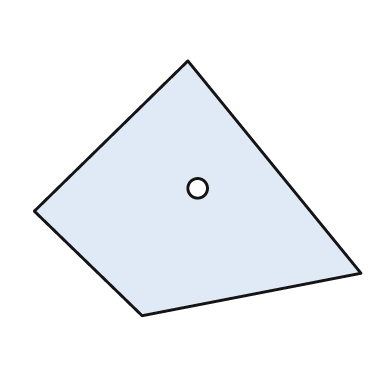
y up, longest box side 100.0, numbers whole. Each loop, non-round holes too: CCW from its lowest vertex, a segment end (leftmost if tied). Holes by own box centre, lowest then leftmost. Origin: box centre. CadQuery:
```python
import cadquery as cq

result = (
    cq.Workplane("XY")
    .moveTo(-17.0, -39.0)
    .lineTo(50.0, -26.0)
    .lineTo(-3.0, 39.0)
    .lineTo(-50.0, -7.0)
    .close()
    .moveTo(0.0, 0.0)
    .circle(3.0)
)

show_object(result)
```